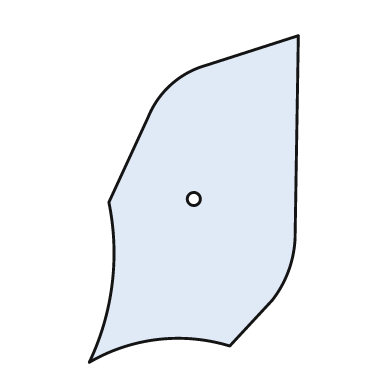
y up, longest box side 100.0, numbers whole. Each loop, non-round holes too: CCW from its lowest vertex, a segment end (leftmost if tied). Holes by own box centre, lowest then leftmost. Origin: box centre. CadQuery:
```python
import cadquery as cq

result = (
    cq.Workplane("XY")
    .moveTo(-32.0, -50.0)
    .threePointArc((-11.0, -43.0), (11.0, -45.0))
    .lineTo(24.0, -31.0)
    .threePointArc((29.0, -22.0), (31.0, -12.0))
    .lineTo(32.0, 50.0)
    .lineTo(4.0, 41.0)
    .threePointArc((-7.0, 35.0), (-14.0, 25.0))
    .lineTo(-26.0, -1.0)
    .threePointArc((-25.0, -26.0), (-32.0, -50.0))
    .close()
    .moveTo(0.0, 0.0)
    .circle(2.0)
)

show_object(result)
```